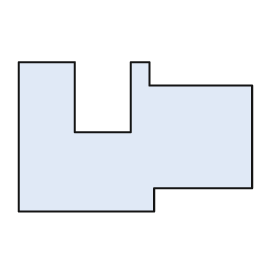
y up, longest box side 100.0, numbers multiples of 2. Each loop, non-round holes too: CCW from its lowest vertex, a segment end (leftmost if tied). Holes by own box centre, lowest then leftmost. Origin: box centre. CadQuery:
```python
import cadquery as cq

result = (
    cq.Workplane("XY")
    .moveTo(-50.0, -32.0)
    .lineTo(8.0, -32.0)
    .lineTo(8.0, -22.0)
    .lineTo(50.0, -22.0)
    .lineTo(50.0, 22.0)
    .lineTo(6.0, 22.0)
    .lineTo(6.0, 32.0)
    .lineTo(-2.0, 32.0)
    .lineTo(-2.0, 2.0)
    .lineTo(-26.0, 2.0)
    .lineTo(-26.0, 32.0)
    .lineTo(-50.0, 32.0)
    .close()
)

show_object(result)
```